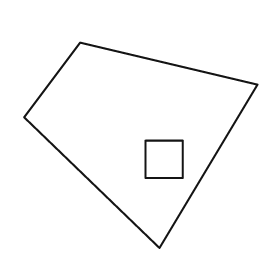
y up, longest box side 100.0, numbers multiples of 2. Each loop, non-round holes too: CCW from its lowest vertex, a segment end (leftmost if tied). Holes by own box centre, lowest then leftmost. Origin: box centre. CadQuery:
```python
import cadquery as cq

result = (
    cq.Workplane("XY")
    .moveTo(8.0, -44.0)
    .lineTo(50.0, 26.0)
    .lineTo(-26.0, 44.0)
    .lineTo(-50.0, 12.0)
    .close()
    .moveTo(2.0, -14.0)
    .lineTo(18.0, -14.0)
    .lineTo(18.0, 2.0)
    .lineTo(2.0, 2.0)
    .close()
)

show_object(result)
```